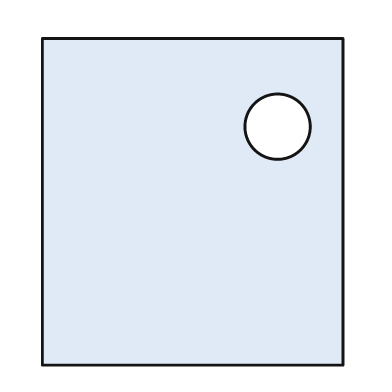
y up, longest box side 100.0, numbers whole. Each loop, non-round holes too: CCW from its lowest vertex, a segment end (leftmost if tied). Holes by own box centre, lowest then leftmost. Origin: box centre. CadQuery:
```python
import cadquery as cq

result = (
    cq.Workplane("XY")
    .moveTo(-46.0, -50.0)
    .lineTo(46.0, -50.0)
    .lineTo(46.0, 50.0)
    .lineTo(-46.0, 50.0)
    .close()
    .moveTo(26.0, 23.0)
    .circle(10.0)
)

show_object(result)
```